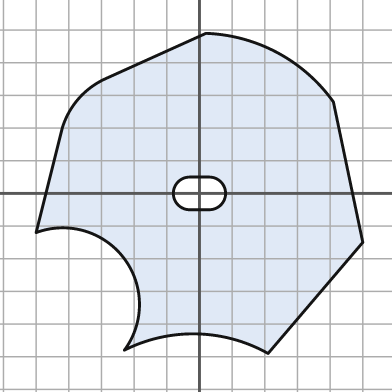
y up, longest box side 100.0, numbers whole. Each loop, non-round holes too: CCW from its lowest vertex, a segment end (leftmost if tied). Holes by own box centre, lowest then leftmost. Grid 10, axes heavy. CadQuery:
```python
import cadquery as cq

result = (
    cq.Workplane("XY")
    .moveTo(21.0, -49.0)
    .lineTo(50.0, -15.0)
    .lineTo(41.0, 28.0)
    .threePointArc((24.0, 43.0), (2.0, 49.0))
    .lineTo(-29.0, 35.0)
    .threePointArc((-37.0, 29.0), (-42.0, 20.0))
    .lineTo(-50.0, -12.0)
    .threePointArc((-23.0, -20.0), (-23.0, -48.0))
    .threePointArc((-1.0, -43.0), (21.0, -49.0))
    .close()
    .moveTo(-3.0, -5.0)
    .lineTo(3.0, -5.0)
    .threePointArc((8.0, 0.0), (3.0, 5.0))
    .lineTo(-3.0, 5.0)
    .threePointArc((-8.0, 0.0), (-3.0, -5.0))
    .close()
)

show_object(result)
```